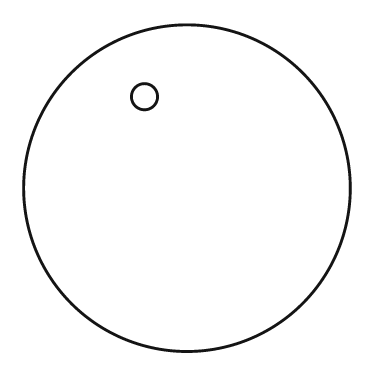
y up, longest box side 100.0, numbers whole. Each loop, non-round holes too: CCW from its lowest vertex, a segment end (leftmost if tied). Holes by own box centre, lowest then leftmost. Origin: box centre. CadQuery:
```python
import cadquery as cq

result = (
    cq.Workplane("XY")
    .moveTo(0.0, 0.0)
    .circle(50.0)
    .moveTo(-13.0, 28.0)
    .circle(4.0)
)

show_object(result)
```